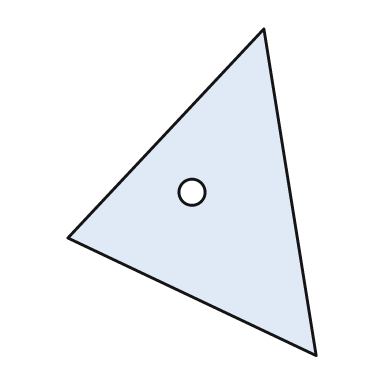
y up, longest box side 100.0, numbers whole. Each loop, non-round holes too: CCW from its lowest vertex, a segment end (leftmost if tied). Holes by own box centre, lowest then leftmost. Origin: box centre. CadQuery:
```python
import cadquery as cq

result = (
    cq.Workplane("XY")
    .moveTo(38.0, -50.0)
    .lineTo(22.0, 50.0)
    .lineTo(-38.0, -14.0)
    .close()
    .moveTo(0.0, 0.0)
    .circle(4.0)
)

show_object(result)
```